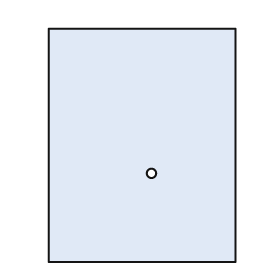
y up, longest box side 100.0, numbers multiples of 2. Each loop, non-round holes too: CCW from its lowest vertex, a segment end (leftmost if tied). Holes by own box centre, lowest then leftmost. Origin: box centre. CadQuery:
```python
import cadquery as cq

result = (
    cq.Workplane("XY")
    .moveTo(-40.0, -50.0)
    .lineTo(40.0, -50.0)
    .lineTo(40.0, 50.0)
    .lineTo(-40.0, 50.0)
    .close()
    .moveTo(4.0, -12.0)
    .circle(2.0)
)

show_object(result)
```